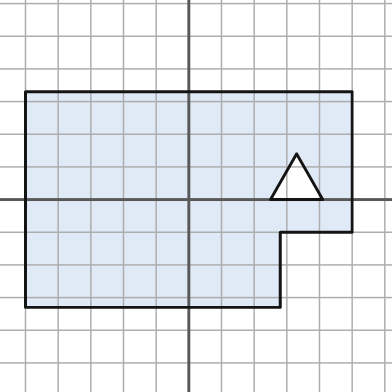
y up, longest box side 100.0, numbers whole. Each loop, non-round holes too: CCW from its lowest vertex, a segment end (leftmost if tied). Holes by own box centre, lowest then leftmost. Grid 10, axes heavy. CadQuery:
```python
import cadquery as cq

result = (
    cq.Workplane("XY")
    .moveTo(-50.0, -33.0)
    .lineTo(28.0, -33.0)
    .lineTo(28.0, -10.0)
    .lineTo(50.0, -10.0)
    .lineTo(50.0, 33.0)
    .lineTo(-50.0, 33.0)
    .close()
    .moveTo(25.0, 0.0)
    .lineTo(41.0, 0.0)
    .lineTo(33.0, 14.0)
    .close()
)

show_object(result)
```